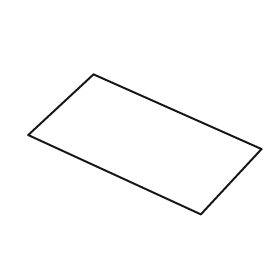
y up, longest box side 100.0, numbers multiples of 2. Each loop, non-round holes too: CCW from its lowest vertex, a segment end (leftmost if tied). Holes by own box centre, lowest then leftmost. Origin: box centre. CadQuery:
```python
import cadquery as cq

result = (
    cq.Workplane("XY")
    .moveTo(24.0, -30.0)
    .lineTo(50.0, -2.0)
    .lineTo(-22.0, 30.0)
    .lineTo(-50.0, 4.0)
    .close()
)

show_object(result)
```